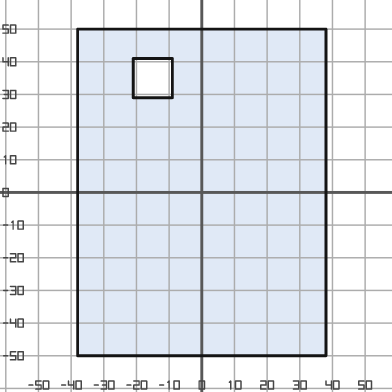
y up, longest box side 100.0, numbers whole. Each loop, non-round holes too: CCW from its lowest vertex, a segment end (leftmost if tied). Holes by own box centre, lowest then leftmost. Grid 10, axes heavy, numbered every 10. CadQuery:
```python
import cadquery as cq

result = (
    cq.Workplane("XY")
    .moveTo(-38.0, -50.0)
    .lineTo(38.0, -50.0)
    .lineTo(38.0, 50.0)
    .lineTo(-38.0, 50.0)
    .close()
    .moveTo(-21.0, 29.0)
    .lineTo(-9.0, 29.0)
    .lineTo(-9.0, 41.0)
    .lineTo(-21.0, 41.0)
    .close()
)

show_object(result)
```